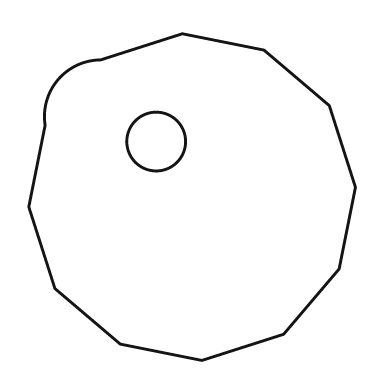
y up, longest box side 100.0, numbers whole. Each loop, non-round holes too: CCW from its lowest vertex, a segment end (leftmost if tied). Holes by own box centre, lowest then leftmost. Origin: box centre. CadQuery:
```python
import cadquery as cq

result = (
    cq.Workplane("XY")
    .moveTo(3.0, -50.0)
    .lineTo(28.0, -42.0)
    .lineTo(45.0, -22.0)
    .lineTo(50.0, 3.0)
    .lineTo(42.0, 28.0)
    .lineTo(22.0, 45.0)
    .lineTo(-3.0, 50.0)
    .lineTo(-28.0, 42.0)
    .threePointArc((-41.0, 36.0), (-45.0, 22.0))
    .lineTo(-50.0, -3.0)
    .lineTo(-42.0, -28.0)
    .lineTo(-22.0, -45.0)
    .close()
    .moveTo(-11.0, 17.0)
    .circle(9.0)
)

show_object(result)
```